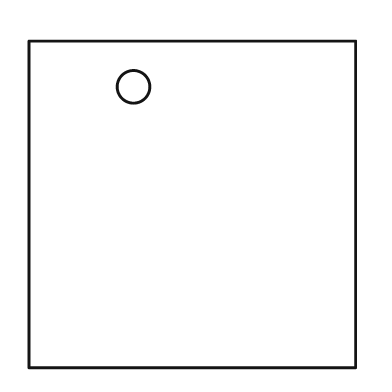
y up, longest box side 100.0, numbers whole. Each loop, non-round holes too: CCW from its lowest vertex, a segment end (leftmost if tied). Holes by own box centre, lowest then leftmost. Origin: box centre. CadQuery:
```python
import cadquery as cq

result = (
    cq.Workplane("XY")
    .moveTo(-50.0, -50.0)
    .lineTo(50.0, -50.0)
    .lineTo(50.0, 50.0)
    .lineTo(-50.0, 50.0)
    .close()
    .moveTo(-18.0, 36.0)
    .circle(5.0)
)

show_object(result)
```